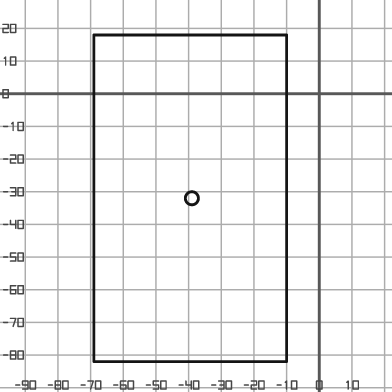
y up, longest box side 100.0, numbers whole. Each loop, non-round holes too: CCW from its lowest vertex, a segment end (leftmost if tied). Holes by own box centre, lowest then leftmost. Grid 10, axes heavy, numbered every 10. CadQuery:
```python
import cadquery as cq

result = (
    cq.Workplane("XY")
    .moveTo(-69.0, -82.0)
    .lineTo(-10.0, -82.0)
    .lineTo(-10.0, 18.0)
    .lineTo(-69.0, 18.0)
    .close()
    .moveTo(-39.0, -32.0)
    .circle(2.0)
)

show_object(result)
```